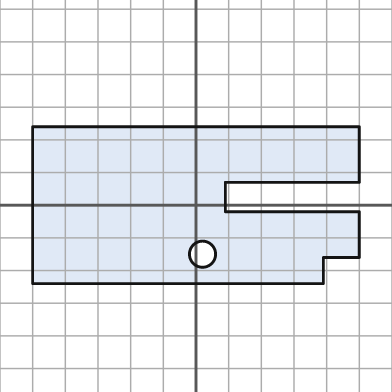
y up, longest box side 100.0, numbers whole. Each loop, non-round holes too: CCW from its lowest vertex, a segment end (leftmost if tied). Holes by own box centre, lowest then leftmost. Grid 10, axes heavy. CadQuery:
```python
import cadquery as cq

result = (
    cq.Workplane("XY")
    .moveTo(-50.0, -24.0)
    .lineTo(39.0, -24.0)
    .lineTo(39.0, -16.0)
    .lineTo(50.0, -16.0)
    .lineTo(50.0, -2.0)
    .lineTo(9.0, -2.0)
    .lineTo(9.0, 7.0)
    .lineTo(50.0, 7.0)
    .lineTo(50.0, 24.0)
    .lineTo(-50.0, 24.0)
    .close()
    .moveTo(2.0, -15.0)
    .circle(4.0)
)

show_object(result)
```